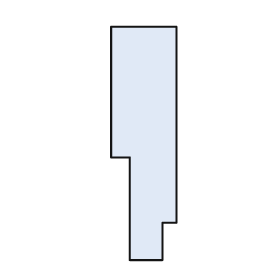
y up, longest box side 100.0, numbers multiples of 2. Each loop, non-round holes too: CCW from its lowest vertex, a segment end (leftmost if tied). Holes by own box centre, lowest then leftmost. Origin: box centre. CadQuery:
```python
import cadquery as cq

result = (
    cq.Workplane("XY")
    .moveTo(-6.0, -50.0)
    .lineTo(8.0, -50.0)
    .lineTo(8.0, -34.0)
    .lineTo(14.0, -34.0)
    .lineTo(14.0, 50.0)
    .lineTo(-14.0, 50.0)
    .lineTo(-14.0, -6.0)
    .lineTo(-6.0, -6.0)
    .close()
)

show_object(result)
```